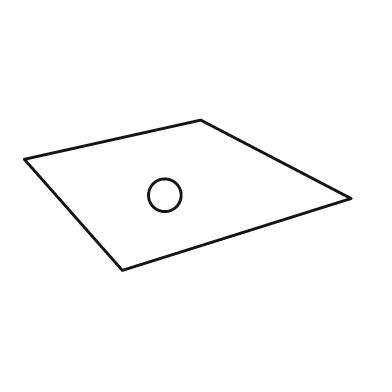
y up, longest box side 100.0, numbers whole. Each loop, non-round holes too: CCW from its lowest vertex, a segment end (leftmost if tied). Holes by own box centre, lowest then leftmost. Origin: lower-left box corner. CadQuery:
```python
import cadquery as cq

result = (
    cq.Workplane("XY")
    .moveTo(30.0, 0.0)
    .lineTo(100.0, 22.0)
    .lineTo(54.0, 46.0)
    .lineTo(0.0, 34.0)
    .close()
    .moveTo(43.0, 23.0)
    .circle(5.0)
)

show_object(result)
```